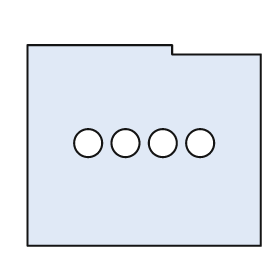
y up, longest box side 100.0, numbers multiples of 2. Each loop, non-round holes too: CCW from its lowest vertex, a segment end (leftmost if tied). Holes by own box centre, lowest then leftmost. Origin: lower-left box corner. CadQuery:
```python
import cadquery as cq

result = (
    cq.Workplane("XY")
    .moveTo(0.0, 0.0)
    .lineTo(100.0, 0.0)
    .lineTo(100.0, 82.0)
    .lineTo(62.0, 82.0)
    .lineTo(62.0, 86.0)
    .lineTo(0.0, 86.0)
    .close()
    .moveTo(26.0, 44.0)
    .circle(6.0)
    .moveTo(42.0, 44.0)
    .circle(6.0)
    .moveTo(58.0, 44.0)
    .circle(6.0)
    .moveTo(74.0, 44.0)
    .circle(6.0)
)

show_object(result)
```